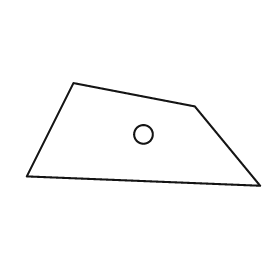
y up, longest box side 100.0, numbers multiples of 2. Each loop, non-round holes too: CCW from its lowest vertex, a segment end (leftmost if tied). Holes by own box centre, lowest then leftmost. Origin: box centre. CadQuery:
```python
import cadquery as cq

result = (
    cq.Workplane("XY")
    .moveTo(50.0, -22.0)
    .lineTo(22.0, 12.0)
    .lineTo(-30.0, 22.0)
    .lineTo(-50.0, -18.0)
    .close()
    .moveTo(0.0, 0.0)
    .circle(4.0)
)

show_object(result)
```